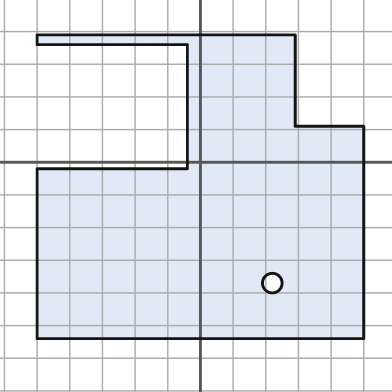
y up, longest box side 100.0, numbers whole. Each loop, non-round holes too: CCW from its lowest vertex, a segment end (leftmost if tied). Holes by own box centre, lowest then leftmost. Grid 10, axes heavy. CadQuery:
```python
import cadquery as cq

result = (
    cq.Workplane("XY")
    .moveTo(-50.0, -54.0)
    .lineTo(50.0, -54.0)
    .lineTo(50.0, 11.0)
    .lineTo(29.0, 11.0)
    .lineTo(29.0, 39.0)
    .lineTo(-50.0, 39.0)
    .lineTo(-50.0, 36.0)
    .lineTo(-4.0, 36.0)
    .lineTo(-4.0, -2.0)
    .lineTo(-50.0, -2.0)
    .close()
    .moveTo(22.0, -37.0)
    .circle(3.0)
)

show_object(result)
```